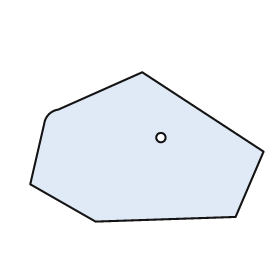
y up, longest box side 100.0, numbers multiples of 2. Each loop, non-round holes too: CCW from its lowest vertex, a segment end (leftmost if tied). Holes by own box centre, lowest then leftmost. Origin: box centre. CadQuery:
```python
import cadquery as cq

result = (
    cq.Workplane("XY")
    .moveTo(-22.0, -32.0)
    .lineTo(38.0, -30.0)
    .lineTo(50.0, -2.0)
    .lineTo(-2.0, 32.0)
    .lineTo(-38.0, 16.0)
    .threePointArc((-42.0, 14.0), (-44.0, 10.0))
    .lineTo(-50.0, -16.0)
    .close()
    .moveTo(6.0, 4.0)
    .circle(2.0)
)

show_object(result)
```